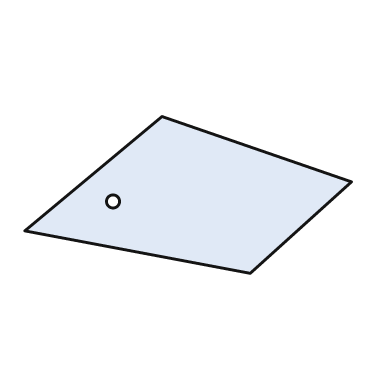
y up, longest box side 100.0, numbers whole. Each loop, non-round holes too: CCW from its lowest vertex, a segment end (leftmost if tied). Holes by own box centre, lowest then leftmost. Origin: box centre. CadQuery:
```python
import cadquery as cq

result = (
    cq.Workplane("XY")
    .moveTo(19.0, -24.0)
    .lineTo(50.0, 4.0)
    .lineTo(-8.0, 24.0)
    .lineTo(-50.0, -11.0)
    .close()
    .moveTo(-23.0, -2.0)
    .circle(2.0)
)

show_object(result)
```